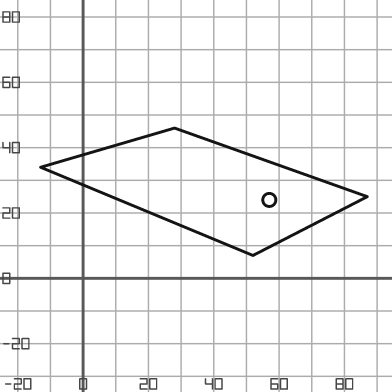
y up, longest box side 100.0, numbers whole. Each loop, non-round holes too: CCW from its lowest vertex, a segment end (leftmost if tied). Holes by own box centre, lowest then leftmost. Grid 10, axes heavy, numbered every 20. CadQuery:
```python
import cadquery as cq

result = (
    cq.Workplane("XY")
    .moveTo(52.0, 7.0)
    .lineTo(87.0, 25.0)
    .lineTo(28.0, 46.0)
    .lineTo(-13.0, 34.0)
    .close()
    .moveTo(57.0, 24.0)
    .circle(2.0)
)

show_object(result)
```